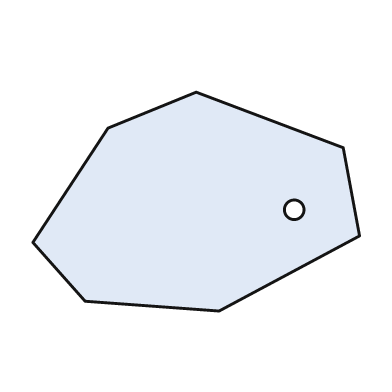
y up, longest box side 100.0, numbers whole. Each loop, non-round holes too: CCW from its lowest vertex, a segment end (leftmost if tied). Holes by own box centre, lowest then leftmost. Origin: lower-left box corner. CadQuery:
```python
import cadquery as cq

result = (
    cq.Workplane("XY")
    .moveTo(57.0, 0.0)
    .lineTo(100.0, 23.0)
    .lineTo(95.0, 50.0)
    .lineTo(50.0, 67.0)
    .lineTo(23.0, 56.0)
    .lineTo(0.0, 21.0)
    .lineTo(16.0, 3.0)
    .close()
    .moveTo(80.0, 31.0)
    .circle(3.0)
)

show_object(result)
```